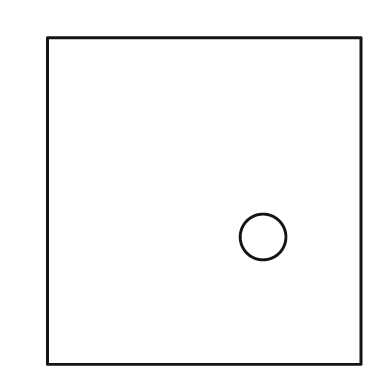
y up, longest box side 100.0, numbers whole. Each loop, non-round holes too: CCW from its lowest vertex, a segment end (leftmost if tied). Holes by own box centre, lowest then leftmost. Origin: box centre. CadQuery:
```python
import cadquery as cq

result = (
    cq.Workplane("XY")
    .moveTo(-48.0, -50.0)
    .lineTo(48.0, -50.0)
    .lineTo(48.0, 50.0)
    .lineTo(-48.0, 50.0)
    .close()
    .moveTo(18.0, -11.0)
    .circle(7.0)
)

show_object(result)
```